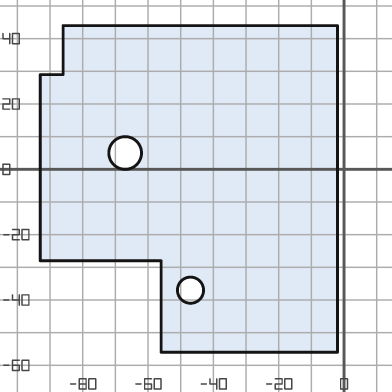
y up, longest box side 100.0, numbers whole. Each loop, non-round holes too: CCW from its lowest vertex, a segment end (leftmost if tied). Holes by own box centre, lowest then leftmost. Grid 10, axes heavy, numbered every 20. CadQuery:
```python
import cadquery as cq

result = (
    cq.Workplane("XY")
    .moveTo(-56.0, -56.0)
    .lineTo(-2.0, -56.0)
    .lineTo(-2.0, 44.0)
    .lineTo(-86.0, 44.0)
    .lineTo(-86.0, 29.0)
    .lineTo(-93.0, 29.0)
    .lineTo(-93.0, -28.0)
    .lineTo(-56.0, -28.0)
    .close()
    .moveTo(-47.0, -37.0)
    .circle(4.0)
    .moveTo(-67.0, 5.0)
    .circle(5.0)
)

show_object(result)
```